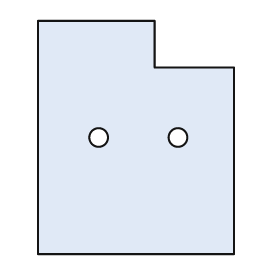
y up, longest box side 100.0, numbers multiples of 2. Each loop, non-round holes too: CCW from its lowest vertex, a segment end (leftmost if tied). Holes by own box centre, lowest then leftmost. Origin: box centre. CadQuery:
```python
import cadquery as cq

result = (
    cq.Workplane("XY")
    .moveTo(-42.0, -50.0)
    .lineTo(42.0, -50.0)
    .lineTo(42.0, 30.0)
    .lineTo(8.0, 30.0)
    .lineTo(8.0, 50.0)
    .lineTo(-42.0, 50.0)
    .close()
    .moveTo(-16.0, 0.0)
    .circle(4.0)
    .moveTo(18.0, 0.0)
    .circle(4.0)
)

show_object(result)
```